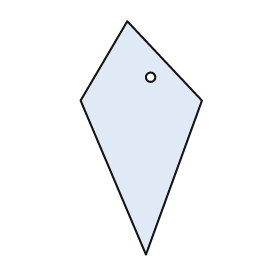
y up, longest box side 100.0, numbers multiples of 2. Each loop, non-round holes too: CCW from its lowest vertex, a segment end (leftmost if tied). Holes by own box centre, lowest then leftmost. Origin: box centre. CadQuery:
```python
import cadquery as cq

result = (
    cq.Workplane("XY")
    .moveTo(2.0, -50.0)
    .lineTo(26.0, 16.0)
    .lineTo(-6.0, 50.0)
    .lineTo(-26.0, 16.0)
    .close()
    .moveTo(4.0, 26.0)
    .circle(2.0)
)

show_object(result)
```